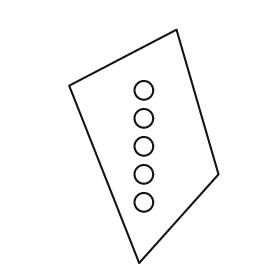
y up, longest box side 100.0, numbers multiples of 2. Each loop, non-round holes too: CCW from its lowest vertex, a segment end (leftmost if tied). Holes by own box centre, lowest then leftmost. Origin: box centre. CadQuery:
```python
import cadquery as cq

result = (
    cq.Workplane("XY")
    .moveTo(-2.0, -50.0)
    .lineTo(32.0, -12.0)
    .lineTo(14.0, 50.0)
    .lineTo(-32.0, 26.0)
    .close()
    .moveTo(0.0, -24.0)
    .circle(4.0)
    .moveTo(0.0, -12.0)
    .circle(4.0)
    .moveTo(0.0, 0.0)
    .circle(4.0)
    .moveTo(0.0, 12.0)
    .circle(4.0)
    .moveTo(0.0, 24.0)
    .circle(4.0)
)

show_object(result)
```